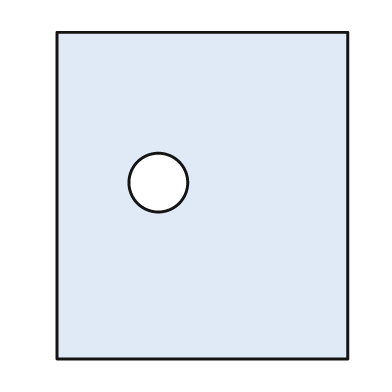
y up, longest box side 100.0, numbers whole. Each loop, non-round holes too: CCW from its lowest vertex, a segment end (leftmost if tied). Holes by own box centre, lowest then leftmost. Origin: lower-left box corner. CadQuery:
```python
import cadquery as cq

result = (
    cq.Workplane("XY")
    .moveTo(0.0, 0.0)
    .lineTo(89.0, 0.0)
    .lineTo(89.0, 100.0)
    .lineTo(0.0, 100.0)
    .close()
    .moveTo(31.0, 54.0)
    .circle(9.0)
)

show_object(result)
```